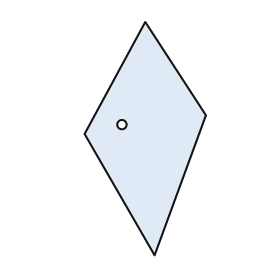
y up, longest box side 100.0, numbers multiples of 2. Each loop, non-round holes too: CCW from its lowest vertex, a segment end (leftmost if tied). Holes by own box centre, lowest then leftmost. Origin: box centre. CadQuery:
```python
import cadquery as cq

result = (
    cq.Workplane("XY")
    .moveTo(4.0, -50.0)
    .lineTo(26.0, 10.0)
    .lineTo(0.0, 50.0)
    .lineTo(-26.0, 2.0)
    .close()
    .moveTo(-10.0, 6.0)
    .circle(2.0)
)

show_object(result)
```